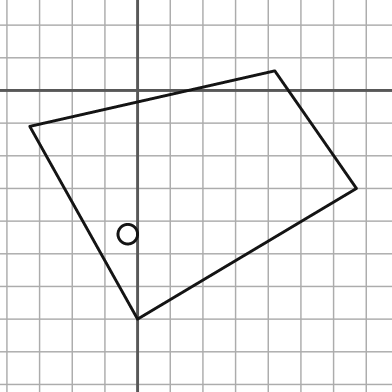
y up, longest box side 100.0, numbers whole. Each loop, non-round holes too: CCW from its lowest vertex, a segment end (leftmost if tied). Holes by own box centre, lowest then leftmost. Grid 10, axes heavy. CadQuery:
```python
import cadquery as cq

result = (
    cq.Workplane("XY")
    .moveTo(0.0, -70.0)
    .lineTo(67.0, -30.0)
    .lineTo(42.0, 6.0)
    .lineTo(-33.0, -11.0)
    .close()
    .moveTo(-3.0, -44.0)
    .circle(3.0)
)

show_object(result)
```